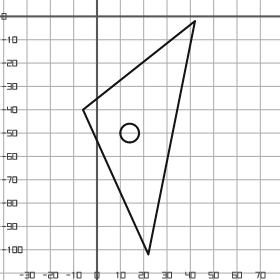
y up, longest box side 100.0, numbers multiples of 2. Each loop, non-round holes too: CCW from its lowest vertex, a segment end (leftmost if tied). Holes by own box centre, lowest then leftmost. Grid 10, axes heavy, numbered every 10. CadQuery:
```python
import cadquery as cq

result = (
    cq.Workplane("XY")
    .moveTo(22.0, -102.0)
    .lineTo(42.0, -2.0)
    .lineTo(-6.0, -40.0)
    .close()
    .moveTo(14.0, -50.0)
    .circle(4.0)
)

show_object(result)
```